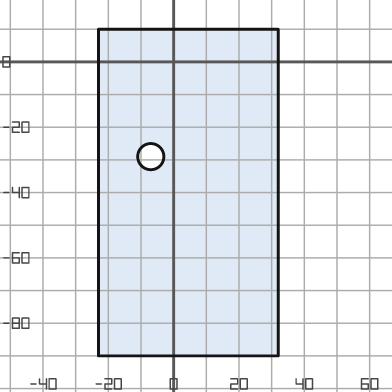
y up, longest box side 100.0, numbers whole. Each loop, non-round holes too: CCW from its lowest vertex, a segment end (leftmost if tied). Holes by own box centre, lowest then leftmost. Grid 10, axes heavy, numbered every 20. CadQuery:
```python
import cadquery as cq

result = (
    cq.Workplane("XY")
    .moveTo(-23.0, -90.0)
    .lineTo(32.0, -90.0)
    .lineTo(32.0, 10.0)
    .lineTo(-23.0, 10.0)
    .close()
    .moveTo(-7.0, -29.0)
    .circle(4.0)
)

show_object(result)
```